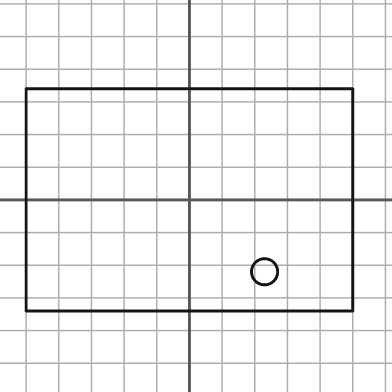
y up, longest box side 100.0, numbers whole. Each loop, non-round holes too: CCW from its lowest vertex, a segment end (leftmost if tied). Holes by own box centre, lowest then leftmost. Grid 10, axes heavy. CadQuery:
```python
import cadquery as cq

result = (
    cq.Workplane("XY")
    .moveTo(-50.0, -34.0)
    .lineTo(50.0, -34.0)
    .lineTo(50.0, 34.0)
    .lineTo(-50.0, 34.0)
    .close()
    .moveTo(23.0, -22.0)
    .circle(4.0)
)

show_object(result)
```